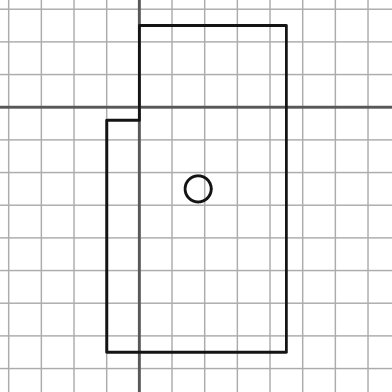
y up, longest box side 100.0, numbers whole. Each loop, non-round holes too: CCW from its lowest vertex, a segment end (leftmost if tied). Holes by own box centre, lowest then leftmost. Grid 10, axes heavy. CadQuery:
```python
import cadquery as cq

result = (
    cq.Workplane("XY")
    .moveTo(-10.0, -75.0)
    .lineTo(45.0, -75.0)
    .lineTo(45.0, 25.0)
    .lineTo(0.0, 25.0)
    .lineTo(0.0, -4.0)
    .lineTo(-10.0, -4.0)
    .close()
    .moveTo(18.0, -25.0)
    .circle(4.0)
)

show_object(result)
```